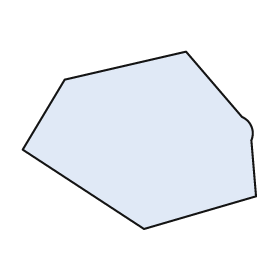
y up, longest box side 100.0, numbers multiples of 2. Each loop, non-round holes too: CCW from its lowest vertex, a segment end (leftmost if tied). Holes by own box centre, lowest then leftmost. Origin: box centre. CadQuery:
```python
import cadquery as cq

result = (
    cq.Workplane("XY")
    .moveTo(2.0, -38.0)
    .lineTo(50.0, -24.0)
    .lineTo(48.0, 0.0)
    .threePointArc((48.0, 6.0), (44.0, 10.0))
    .lineTo(20.0, 38.0)
    .lineTo(-32.0, 26.0)
    .lineTo(-50.0, -4.0)
    .close()
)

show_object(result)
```